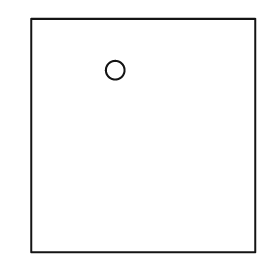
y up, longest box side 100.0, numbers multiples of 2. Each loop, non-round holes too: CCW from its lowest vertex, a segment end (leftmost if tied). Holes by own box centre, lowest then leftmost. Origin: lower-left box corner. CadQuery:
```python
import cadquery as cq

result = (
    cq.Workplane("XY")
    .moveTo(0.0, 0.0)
    .lineTo(96.0, 0.0)
    .lineTo(96.0, 100.0)
    .lineTo(0.0, 100.0)
    .close()
    .moveTo(36.0, 78.0)
    .circle(4.0)
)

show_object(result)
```